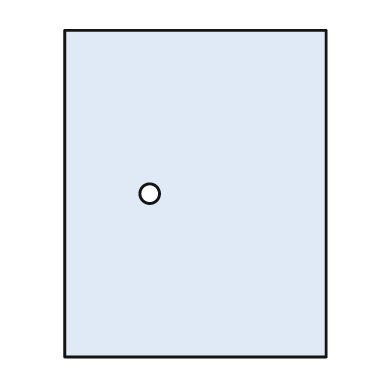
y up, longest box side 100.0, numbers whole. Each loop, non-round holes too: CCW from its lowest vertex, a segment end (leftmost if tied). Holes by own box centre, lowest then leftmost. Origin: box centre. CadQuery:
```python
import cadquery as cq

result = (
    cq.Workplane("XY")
    .moveTo(-40.0, -50.0)
    .lineTo(40.0, -50.0)
    .lineTo(40.0, 50.0)
    .lineTo(-40.0, 50.0)
    .close()
    .moveTo(-14.0, 0.0)
    .circle(3.0)
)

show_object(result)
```